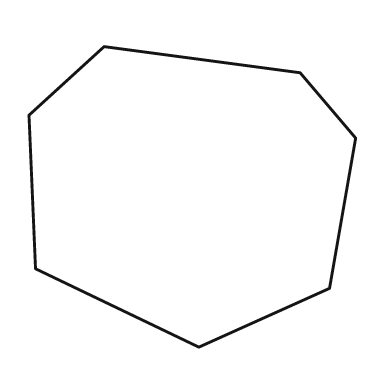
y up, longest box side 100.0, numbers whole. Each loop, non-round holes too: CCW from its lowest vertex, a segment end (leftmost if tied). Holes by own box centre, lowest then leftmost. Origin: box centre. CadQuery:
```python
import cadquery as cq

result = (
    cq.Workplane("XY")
    .moveTo(2.0, -46.0)
    .lineTo(42.0, -28.0)
    .lineTo(50.0, 18.0)
    .lineTo(33.0, 38.0)
    .lineTo(-27.0, 46.0)
    .lineTo(-50.0, 25.0)
    .lineTo(-48.0, -22.0)
    .close()
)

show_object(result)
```